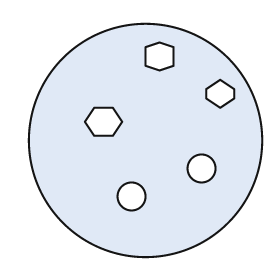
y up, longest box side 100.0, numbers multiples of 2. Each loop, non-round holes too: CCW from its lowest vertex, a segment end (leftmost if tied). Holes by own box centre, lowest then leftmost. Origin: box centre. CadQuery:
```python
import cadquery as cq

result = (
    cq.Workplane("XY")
    .moveTo(0.0, 0.0)
    .circle(50.0)
    .moveTo(-6.0, -24.0)
    .circle(6.0)
    .moveTo(24.0, -12.0)
    .circle(6.0)
    .moveTo(-22.0, 2.0)
    .lineTo(-14.0, 2.0)
    .lineTo(-10.0, 8.0)
    .lineTo(-14.0, 14.0)
    .lineTo(-22.0, 14.0)
    .lineTo(-26.0, 8.0)
    .close()
    .moveTo(32.0, 14.0)
    .lineTo(38.0, 18.0)
    .lineTo(38.0, 22.0)
    .lineTo(32.0, 26.0)
    .lineTo(26.0, 22.0)
    .lineTo(26.0, 18.0)
    .close()
    .moveTo(6.0, 30.0)
    .lineTo(12.0, 32.0)
    .lineTo(12.0, 40.0)
    .lineTo(6.0, 42.0)
    .lineTo(0.0, 40.0)
    .lineTo(0.0, 32.0)
    .close()
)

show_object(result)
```